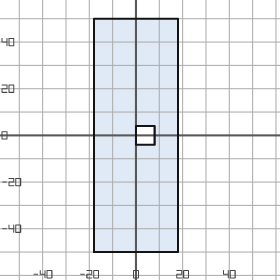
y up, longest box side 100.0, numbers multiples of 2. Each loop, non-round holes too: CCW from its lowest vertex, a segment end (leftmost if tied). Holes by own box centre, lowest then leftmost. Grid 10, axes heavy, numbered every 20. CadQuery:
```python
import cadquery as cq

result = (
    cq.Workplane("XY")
    .moveTo(-18.0, -50.0)
    .lineTo(18.0, -50.0)
    .lineTo(18.0, 50.0)
    .lineTo(-18.0, 50.0)
    .close()
    .moveTo(0.0, -4.0)
    .lineTo(8.0, -4.0)
    .lineTo(8.0, 4.0)
    .lineTo(0.0, 4.0)
    .close()
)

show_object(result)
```